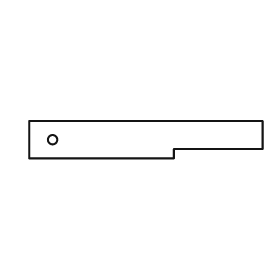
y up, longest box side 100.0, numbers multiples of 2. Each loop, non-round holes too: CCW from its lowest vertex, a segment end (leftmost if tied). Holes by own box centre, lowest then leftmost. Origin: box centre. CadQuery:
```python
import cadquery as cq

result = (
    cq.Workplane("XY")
    .moveTo(-50.0, -8.0)
    .lineTo(12.0, -8.0)
    .lineTo(12.0, -4.0)
    .lineTo(50.0, -4.0)
    .lineTo(50.0, 8.0)
    .lineTo(-50.0, 8.0)
    .close()
    .moveTo(-40.0, 0.0)
    .circle(2.0)
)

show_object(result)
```